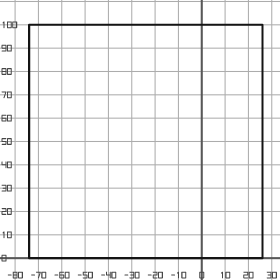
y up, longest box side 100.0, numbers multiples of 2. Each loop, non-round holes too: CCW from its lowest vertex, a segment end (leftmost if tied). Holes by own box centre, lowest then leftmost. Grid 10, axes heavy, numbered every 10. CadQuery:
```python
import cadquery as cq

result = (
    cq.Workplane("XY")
    .moveTo(-74.0, 0.0)
    .lineTo(26.0, 0.0)
    .lineTo(26.0, 100.0)
    .lineTo(-74.0, 100.0)
    .close()
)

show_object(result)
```